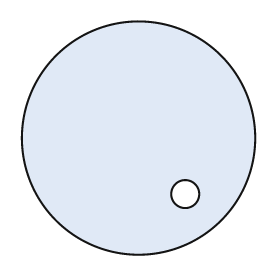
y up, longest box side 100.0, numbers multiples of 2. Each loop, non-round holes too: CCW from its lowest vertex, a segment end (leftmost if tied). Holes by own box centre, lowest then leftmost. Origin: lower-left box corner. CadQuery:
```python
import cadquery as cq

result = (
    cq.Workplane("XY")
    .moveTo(50.0, 50.0)
    .circle(50.0)
    .moveTo(70.0, 26.0)
    .circle(6.0)
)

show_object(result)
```